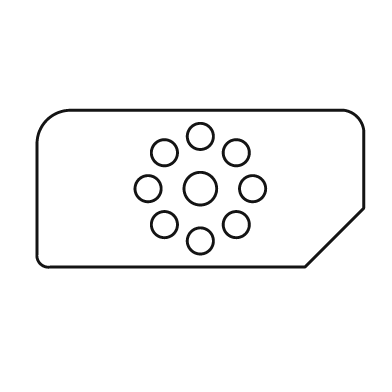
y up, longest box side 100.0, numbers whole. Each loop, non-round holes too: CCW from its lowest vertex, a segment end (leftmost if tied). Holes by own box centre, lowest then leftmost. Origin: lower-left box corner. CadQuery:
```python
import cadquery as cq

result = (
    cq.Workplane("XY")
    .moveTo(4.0, 0.0)
    .lineTo(82.0, 0.0)
    .lineTo(100.0, 18.0)
    .lineTo(100.0, 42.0)
    .threePointArc((98.0, 46.0), (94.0, 48.0))
    .lineTo(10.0, 48.0)
    .threePointArc((3.0, 45.0), (0.0, 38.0))
    .lineTo(0.0, 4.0)
    .threePointArc((1.0, 1.0), (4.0, 0.0))
    .close()
    .moveTo(50.0, 8.0)
    .circle(4.0)
    .moveTo(39.0, 13.0)
    .circle(4.0)
    .moveTo(61.0, 13.0)
    .circle(4.0)
    .moveTo(34.0, 24.0)
    .circle(4.0)
    .moveTo(50.0, 24.0)
    .circle(5.0)
    .moveTo(66.0, 24.0)
    .circle(4.0)
    .moveTo(39.0, 35.0)
    .circle(4.0)
    .moveTo(61.0, 35.0)
    .circle(4.0)
    .moveTo(50.0, 40.0)
    .circle(4.0)
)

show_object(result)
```